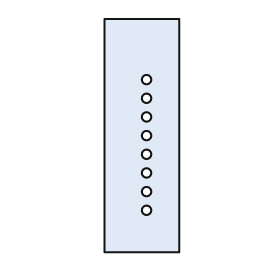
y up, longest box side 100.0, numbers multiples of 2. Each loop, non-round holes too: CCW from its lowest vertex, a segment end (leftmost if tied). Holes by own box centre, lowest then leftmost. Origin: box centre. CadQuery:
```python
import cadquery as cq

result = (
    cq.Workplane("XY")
    .moveTo(-16.0, -50.0)
    .lineTo(16.0, -50.0)
    .lineTo(16.0, 50.0)
    .lineTo(-16.0, 50.0)
    .close()
    .moveTo(2.0, -32.0)
    .circle(2.0)
    .moveTo(2.0, -24.0)
    .circle(2.0)
    .moveTo(2.0, -16.0)
    .circle(2.0)
    .moveTo(2.0, -8.0)
    .circle(2.0)
    .moveTo(2.0, 0.0)
    .circle(2.0)
    .moveTo(2.0, 8.0)
    .circle(2.0)
    .moveTo(2.0, 16.0)
    .circle(2.0)
    .moveTo(2.0, 24.0)
    .circle(2.0)
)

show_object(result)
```